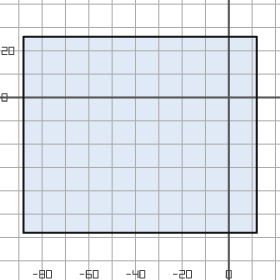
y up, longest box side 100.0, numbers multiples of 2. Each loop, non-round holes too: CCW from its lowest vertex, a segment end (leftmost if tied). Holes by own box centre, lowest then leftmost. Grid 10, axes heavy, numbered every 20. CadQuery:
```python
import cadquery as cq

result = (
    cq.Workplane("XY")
    .moveTo(-88.0, -58.0)
    .lineTo(12.0, -58.0)
    .lineTo(12.0, 26.0)
    .lineTo(-88.0, 26.0)
    .close()
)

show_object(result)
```